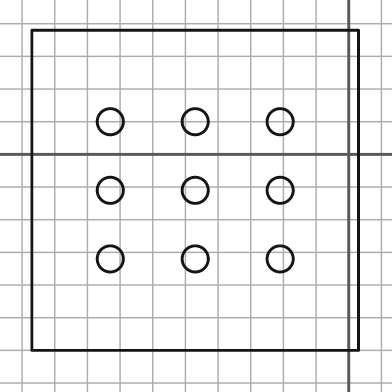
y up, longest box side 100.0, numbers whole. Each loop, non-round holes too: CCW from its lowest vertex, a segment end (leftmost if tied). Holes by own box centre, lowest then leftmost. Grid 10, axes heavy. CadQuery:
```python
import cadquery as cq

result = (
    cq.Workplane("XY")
    .moveTo(-97.0, -60.0)
    .lineTo(3.0, -60.0)
    .lineTo(3.0, 38.0)
    .lineTo(-97.0, 38.0)
    .close()
    .moveTo(-73.0, -32.0)
    .circle(4.0)
    .moveTo(-47.0, -32.0)
    .circle(4.0)
    .moveTo(-21.0, -32.0)
    .circle(4.0)
    .moveTo(-73.0, -11.0)
    .circle(4.0)
    .moveTo(-47.0, -11.0)
    .circle(4.0)
    .moveTo(-21.0, -11.0)
    .circle(4.0)
    .moveTo(-73.0, 10.0)
    .circle(4.0)
    .moveTo(-47.0, 10.0)
    .circle(4.0)
    .moveTo(-21.0, 10.0)
    .circle(4.0)
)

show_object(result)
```